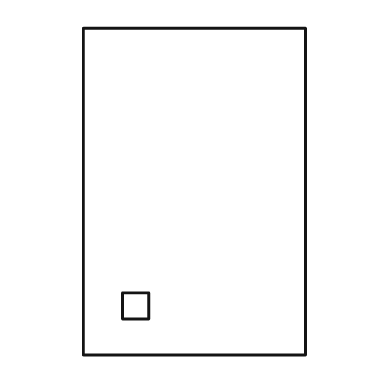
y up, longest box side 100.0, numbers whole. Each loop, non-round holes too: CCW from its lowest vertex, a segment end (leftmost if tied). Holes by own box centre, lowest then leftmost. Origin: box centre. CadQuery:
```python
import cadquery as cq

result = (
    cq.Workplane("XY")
    .moveTo(-34.0, -50.0)
    .lineTo(34.0, -50.0)
    .lineTo(34.0, 50.0)
    .lineTo(-34.0, 50.0)
    .close()
    .moveTo(-22.0, -39.0)
    .lineTo(-14.0, -39.0)
    .lineTo(-14.0, -31.0)
    .lineTo(-22.0, -31.0)
    .close()
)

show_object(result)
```